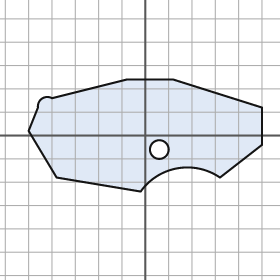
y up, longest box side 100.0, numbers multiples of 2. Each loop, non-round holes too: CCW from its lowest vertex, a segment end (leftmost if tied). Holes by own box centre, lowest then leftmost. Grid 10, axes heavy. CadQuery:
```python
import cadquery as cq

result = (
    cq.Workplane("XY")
    .moveTo(-2.0, -24.0)
    .threePointArc((14.0, -14.0), (32.0, -18.0))
    .lineTo(50.0, -4.0)
    .lineTo(50.0, 12.0)
    .lineTo(12.0, 24.0)
    .lineTo(-8.0, 24.0)
    .lineTo(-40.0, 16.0)
    .threePointArc((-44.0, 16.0), (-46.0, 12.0))
    .lineTo(-50.0, 2.0)
    .lineTo(-38.0, -18.0)
    .close()
    .moveTo(6.0, -6.0)
    .circle(4.0)
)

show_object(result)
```